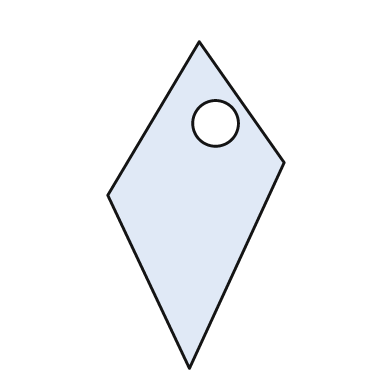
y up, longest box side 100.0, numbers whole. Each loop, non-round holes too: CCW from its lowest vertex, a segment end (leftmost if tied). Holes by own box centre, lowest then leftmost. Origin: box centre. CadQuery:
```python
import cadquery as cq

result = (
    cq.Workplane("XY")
    .moveTo(-2.0, -50.0)
    .lineTo(27.0, 13.0)
    .lineTo(1.0, 50.0)
    .lineTo(-27.0, 3.0)
    .close()
    .moveTo(6.0, 25.0)
    .circle(7.0)
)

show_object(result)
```